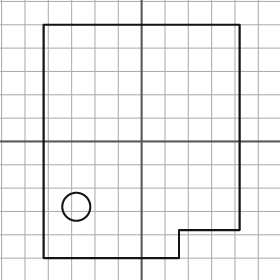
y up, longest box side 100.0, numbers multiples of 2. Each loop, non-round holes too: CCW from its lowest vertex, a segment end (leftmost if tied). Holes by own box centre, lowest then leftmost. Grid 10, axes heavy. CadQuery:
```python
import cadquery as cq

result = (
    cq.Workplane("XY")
    .moveTo(-42.0, -50.0)
    .lineTo(16.0, -50.0)
    .lineTo(16.0, -38.0)
    .lineTo(42.0, -38.0)
    .lineTo(42.0, 50.0)
    .lineTo(-42.0, 50.0)
    .close()
    .moveTo(-28.0, -28.0)
    .circle(6.0)
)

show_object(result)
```